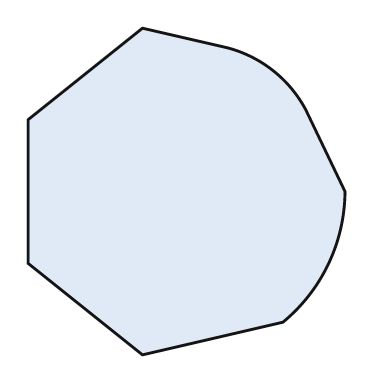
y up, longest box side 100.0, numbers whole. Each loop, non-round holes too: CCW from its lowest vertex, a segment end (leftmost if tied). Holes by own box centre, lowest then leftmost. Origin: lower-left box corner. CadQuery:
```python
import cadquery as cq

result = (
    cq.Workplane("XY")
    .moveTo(35.0, 0.0)
    .lineTo(78.0, 10.0)
    .threePointArc((92.0, 28.0), (97.0, 50.0))
    .lineTo(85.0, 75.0)
    .threePointArc((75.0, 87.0), (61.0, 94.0))
    .lineTo(35.0, 100.0)
    .lineTo(0.0, 72.0)
    .lineTo(0.0, 28.0)
    .close()
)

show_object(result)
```